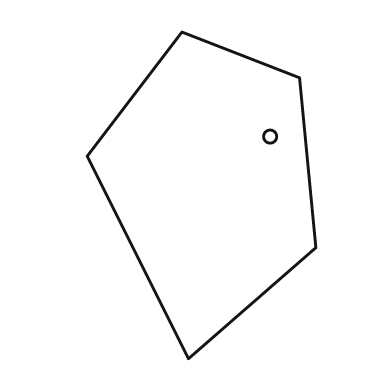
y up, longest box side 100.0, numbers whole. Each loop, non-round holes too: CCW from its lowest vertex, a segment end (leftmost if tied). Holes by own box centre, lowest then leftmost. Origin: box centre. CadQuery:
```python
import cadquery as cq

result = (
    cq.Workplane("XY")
    .moveTo(-4.0, -50.0)
    .lineTo(35.0, -16.0)
    .lineTo(30.0, 36.0)
    .lineTo(-6.0, 50.0)
    .lineTo(-35.0, 12.0)
    .close()
    .moveTo(21.0, 18.0)
    .circle(2.0)
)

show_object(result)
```